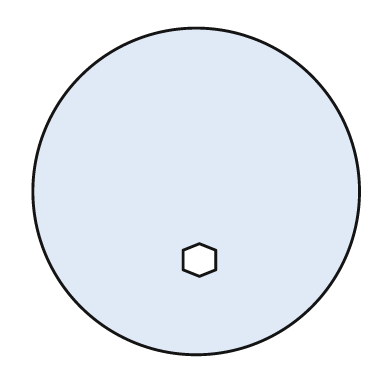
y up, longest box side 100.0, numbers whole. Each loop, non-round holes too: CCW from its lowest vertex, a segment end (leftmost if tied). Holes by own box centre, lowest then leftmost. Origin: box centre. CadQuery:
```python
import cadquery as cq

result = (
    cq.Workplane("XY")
    .moveTo(0.0, 0.0)
    .circle(50.0)
    .moveTo(1.0, -26.0)
    .lineTo(6.0, -24.0)
    .lineTo(6.0, -18.0)
    .lineTo(1.0, -16.0)
    .lineTo(-4.0, -18.0)
    .lineTo(-4.0, -24.0)
    .close()
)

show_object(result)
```